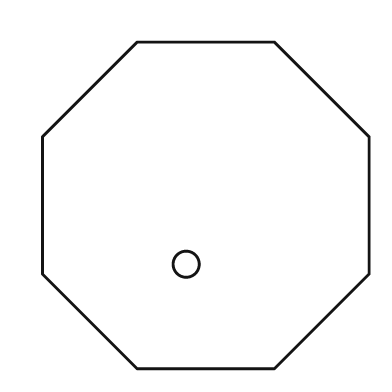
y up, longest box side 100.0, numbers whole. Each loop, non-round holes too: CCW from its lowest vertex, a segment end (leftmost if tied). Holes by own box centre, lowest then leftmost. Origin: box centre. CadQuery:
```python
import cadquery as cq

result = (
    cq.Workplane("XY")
    .moveTo(-21.0, -50.0)
    .lineTo(21.0, -50.0)
    .lineTo(50.0, -21.0)
    .lineTo(50.0, 21.0)
    .lineTo(21.0, 50.0)
    .lineTo(-21.0, 50.0)
    .lineTo(-50.0, 21.0)
    .lineTo(-50.0, -21.0)
    .close()
    .moveTo(-6.0, -18.0)
    .circle(4.0)
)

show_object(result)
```